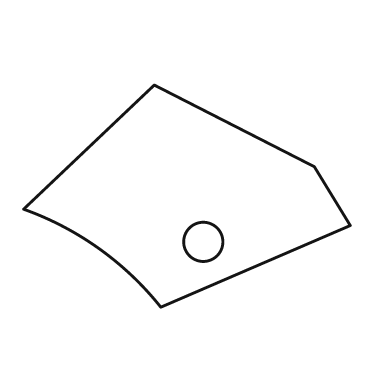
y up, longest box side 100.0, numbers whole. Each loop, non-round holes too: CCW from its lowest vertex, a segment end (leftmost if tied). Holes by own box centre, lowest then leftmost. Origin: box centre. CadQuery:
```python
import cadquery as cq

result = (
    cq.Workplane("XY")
    .moveTo(-8.0, -34.0)
    .lineTo(50.0, -9.0)
    .lineTo(39.0, 9.0)
    .lineTo(-10.0, 34.0)
    .lineTo(-50.0, -4.0)
    .threePointArc((-27.0, -16.0), (-8.0, -34.0))
    .close()
    .moveTo(5.0, -14.0)
    .circle(6.0)
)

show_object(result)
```